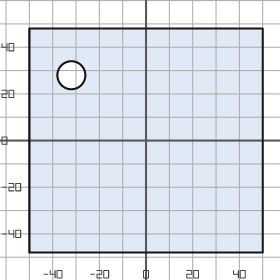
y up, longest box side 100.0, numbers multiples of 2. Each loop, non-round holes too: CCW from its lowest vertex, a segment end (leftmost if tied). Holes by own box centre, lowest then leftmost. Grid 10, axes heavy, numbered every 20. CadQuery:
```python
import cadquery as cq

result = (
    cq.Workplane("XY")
    .moveTo(-50.0, -48.0)
    .lineTo(50.0, -48.0)
    .lineTo(50.0, 48.0)
    .lineTo(-50.0, 48.0)
    .close()
    .moveTo(-32.0, 28.0)
    .circle(6.0)
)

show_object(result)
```